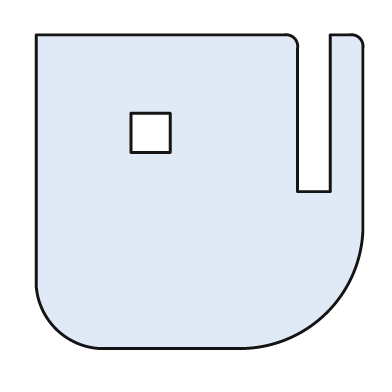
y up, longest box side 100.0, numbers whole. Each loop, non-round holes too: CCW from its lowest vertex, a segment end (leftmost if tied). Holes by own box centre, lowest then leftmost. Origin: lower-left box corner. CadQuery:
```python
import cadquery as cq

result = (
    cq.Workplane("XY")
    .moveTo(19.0, 0.0)
    .lineTo(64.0, 0.0)
    .threePointArc((89.0, 11.0), (100.0, 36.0))
    .lineTo(100.0, 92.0)
    .threePointArc((99.0, 95.0), (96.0, 96.0))
    .lineTo(90.0, 96.0)
    .lineTo(90.0, 48.0)
    .lineTo(80.0, 48.0)
    .lineTo(80.0, 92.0)
    .threePointArc((79.0, 95.0), (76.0, 96.0))
    .lineTo(0.0, 96.0)
    .lineTo(0.0, 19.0)
    .threePointArc((6.0, 6.0), (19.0, 0.0))
    .close()
    .moveTo(29.0, 60.0)
    .lineTo(41.0, 60.0)
    .lineTo(41.0, 72.0)
    .lineTo(29.0, 72.0)
    .close()
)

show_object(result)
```